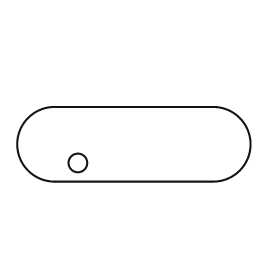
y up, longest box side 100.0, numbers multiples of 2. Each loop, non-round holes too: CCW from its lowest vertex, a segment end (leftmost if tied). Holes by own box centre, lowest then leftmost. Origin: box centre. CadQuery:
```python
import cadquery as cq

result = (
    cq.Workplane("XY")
    .moveTo(-34.0, -16.0)
    .lineTo(34.0, -16.0)
    .threePointArc((50.0, 0.0), (34.0, 16.0))
    .lineTo(-34.0, 16.0)
    .threePointArc((-50.0, 0.0), (-34.0, -16.0))
    .close()
    .moveTo(-24.0, -8.0)
    .circle(4.0)
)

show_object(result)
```